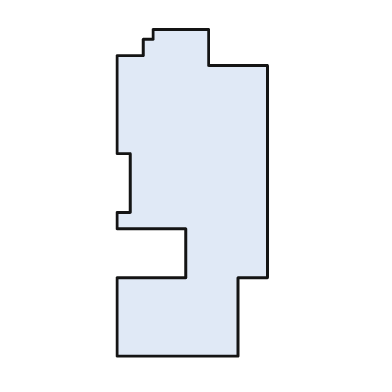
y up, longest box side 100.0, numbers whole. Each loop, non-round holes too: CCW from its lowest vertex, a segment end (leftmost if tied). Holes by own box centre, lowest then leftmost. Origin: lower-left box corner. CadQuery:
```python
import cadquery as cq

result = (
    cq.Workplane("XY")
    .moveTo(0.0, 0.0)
    .lineTo(37.0, 0.0)
    .lineTo(37.0, 24.0)
    .lineTo(46.0, 24.0)
    .lineTo(46.0, 89.0)
    .lineTo(28.0, 89.0)
    .lineTo(28.0, 100.0)
    .lineTo(11.0, 100.0)
    .lineTo(11.0, 97.0)
    .lineTo(8.0, 97.0)
    .lineTo(8.0, 92.0)
    .lineTo(0.0, 92.0)
    .lineTo(0.0, 62.0)
    .lineTo(4.0, 62.0)
    .lineTo(4.0, 44.0)
    .lineTo(0.0, 44.0)
    .lineTo(0.0, 39.0)
    .lineTo(21.0, 39.0)
    .lineTo(21.0, 24.0)
    .lineTo(0.0, 24.0)
    .close()
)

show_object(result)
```